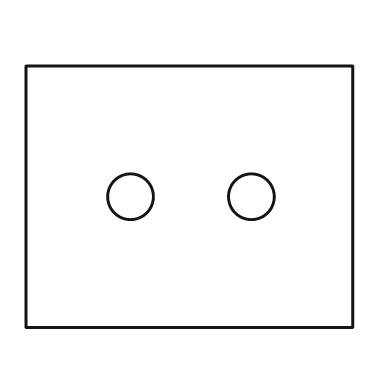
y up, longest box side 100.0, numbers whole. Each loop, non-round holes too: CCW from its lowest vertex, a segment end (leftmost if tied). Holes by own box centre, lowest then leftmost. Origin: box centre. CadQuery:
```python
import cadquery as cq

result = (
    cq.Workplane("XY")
    .moveTo(-50.0, -40.0)
    .lineTo(50.0, -40.0)
    .lineTo(50.0, 40.0)
    .lineTo(-50.0, 40.0)
    .close()
    .moveTo(-18.0, 0.0)
    .circle(7.0)
    .moveTo(19.0, 0.0)
    .circle(7.0)
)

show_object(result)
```